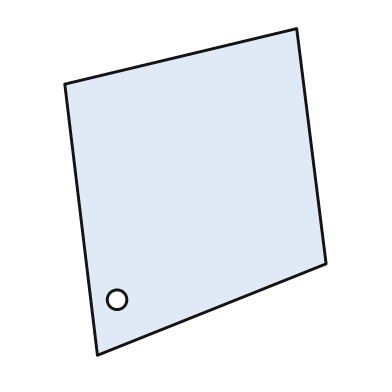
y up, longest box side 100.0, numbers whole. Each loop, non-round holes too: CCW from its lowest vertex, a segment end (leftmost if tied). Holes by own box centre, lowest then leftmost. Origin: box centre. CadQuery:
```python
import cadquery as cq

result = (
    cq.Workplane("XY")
    .moveTo(-30.0, -50.0)
    .lineTo(40.0, -22.0)
    .lineTo(31.0, 50.0)
    .lineTo(-40.0, 33.0)
    .close()
    .moveTo(-24.0, -33.0)
    .circle(3.0)
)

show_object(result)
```